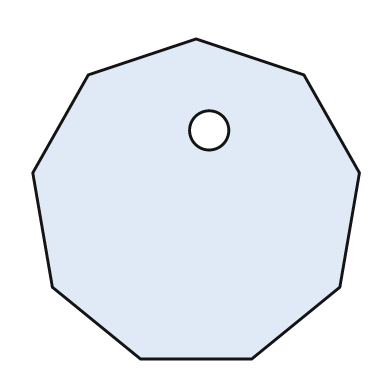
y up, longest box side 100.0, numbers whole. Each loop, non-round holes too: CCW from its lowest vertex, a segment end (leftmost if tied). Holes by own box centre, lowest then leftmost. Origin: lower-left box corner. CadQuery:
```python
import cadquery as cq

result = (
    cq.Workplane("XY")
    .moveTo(33.0, 0.0)
    .lineTo(67.0, 0.0)
    .lineTo(94.0, 22.0)
    .lineTo(100.0, 57.0)
    .lineTo(83.0, 87.0)
    .lineTo(50.0, 98.0)
    .lineTo(17.0, 87.0)
    .lineTo(0.0, 57.0)
    .lineTo(6.0, 22.0)
    .close()
    .moveTo(54.0, 70.0)
    .circle(6.0)
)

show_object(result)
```